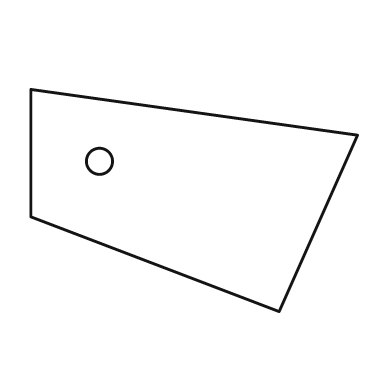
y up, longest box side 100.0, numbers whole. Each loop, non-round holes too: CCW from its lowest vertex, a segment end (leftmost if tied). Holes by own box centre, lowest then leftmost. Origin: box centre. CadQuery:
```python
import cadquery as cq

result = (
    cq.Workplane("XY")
    .moveTo(26.0, -34.0)
    .lineTo(50.0, 20.0)
    .lineTo(-50.0, 34.0)
    .lineTo(-50.0, -5.0)
    .close()
    .moveTo(-29.0, 12.0)
    .circle(4.0)
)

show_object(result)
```